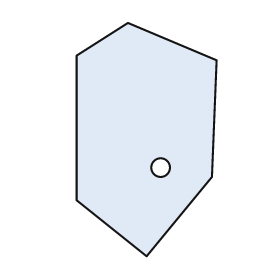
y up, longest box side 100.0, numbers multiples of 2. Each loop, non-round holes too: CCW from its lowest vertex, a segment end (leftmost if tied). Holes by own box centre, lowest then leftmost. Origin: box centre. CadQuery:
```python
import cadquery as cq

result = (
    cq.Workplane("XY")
    .moveTo(0.0, -50.0)
    .lineTo(28.0, -16.0)
    .lineTo(30.0, 34.0)
    .lineTo(-8.0, 50.0)
    .lineTo(-30.0, 36.0)
    .lineTo(-30.0, -26.0)
    .close()
    .moveTo(6.0, -12.0)
    .circle(4.0)
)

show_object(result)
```